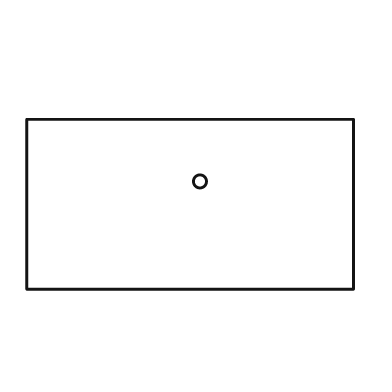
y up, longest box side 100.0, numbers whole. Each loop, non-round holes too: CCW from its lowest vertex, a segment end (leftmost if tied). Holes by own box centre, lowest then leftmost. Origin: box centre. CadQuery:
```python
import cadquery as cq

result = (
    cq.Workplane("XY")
    .moveTo(-50.0, -26.0)
    .lineTo(50.0, -26.0)
    .lineTo(50.0, 26.0)
    .lineTo(-50.0, 26.0)
    .close()
    .moveTo(3.0, 7.0)
    .circle(2.0)
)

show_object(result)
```